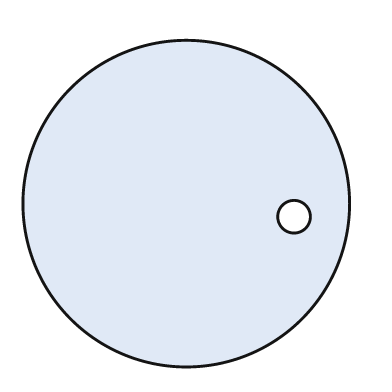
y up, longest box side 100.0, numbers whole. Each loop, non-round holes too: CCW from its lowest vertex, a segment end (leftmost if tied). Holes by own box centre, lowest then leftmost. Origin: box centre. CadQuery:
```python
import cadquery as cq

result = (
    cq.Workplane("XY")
    .moveTo(0.0, 0.0)
    .circle(50.0)
    .moveTo(33.0, -4.0)
    .circle(5.0)
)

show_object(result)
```